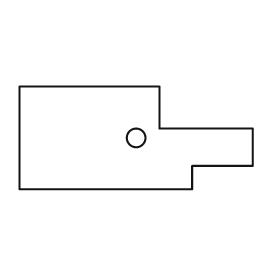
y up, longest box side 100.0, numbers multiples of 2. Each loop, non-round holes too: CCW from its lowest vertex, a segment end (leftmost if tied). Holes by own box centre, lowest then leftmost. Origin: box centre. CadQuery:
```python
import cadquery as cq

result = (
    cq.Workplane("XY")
    .moveTo(-50.0, -22.0)
    .lineTo(24.0, -22.0)
    .lineTo(24.0, -12.0)
    .lineTo(50.0, -12.0)
    .lineTo(50.0, 4.0)
    .lineTo(10.0, 4.0)
    .lineTo(10.0, 22.0)
    .lineTo(-50.0, 22.0)
    .close()
    .moveTo(0.0, 0.0)
    .circle(4.0)
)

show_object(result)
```